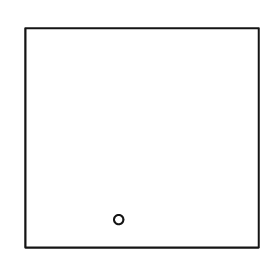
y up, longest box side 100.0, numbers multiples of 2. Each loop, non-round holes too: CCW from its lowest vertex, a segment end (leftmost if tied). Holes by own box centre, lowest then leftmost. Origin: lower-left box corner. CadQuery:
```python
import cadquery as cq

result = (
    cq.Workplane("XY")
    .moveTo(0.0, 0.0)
    .lineTo(100.0, 0.0)
    .lineTo(100.0, 94.0)
    .lineTo(0.0, 94.0)
    .close()
    .moveTo(40.0, 12.0)
    .circle(2.0)
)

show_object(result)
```